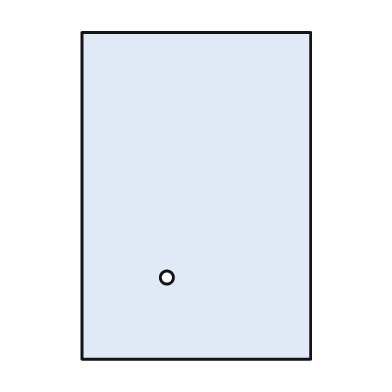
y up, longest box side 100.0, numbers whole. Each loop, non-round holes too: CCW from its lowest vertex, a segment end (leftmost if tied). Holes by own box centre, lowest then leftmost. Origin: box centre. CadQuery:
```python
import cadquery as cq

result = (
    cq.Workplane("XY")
    .moveTo(-35.0, -50.0)
    .lineTo(35.0, -50.0)
    .lineTo(35.0, 50.0)
    .lineTo(-35.0, 50.0)
    .close()
    .moveTo(-9.0, -25.0)
    .circle(2.0)
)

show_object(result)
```